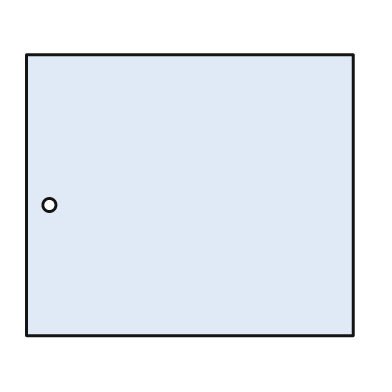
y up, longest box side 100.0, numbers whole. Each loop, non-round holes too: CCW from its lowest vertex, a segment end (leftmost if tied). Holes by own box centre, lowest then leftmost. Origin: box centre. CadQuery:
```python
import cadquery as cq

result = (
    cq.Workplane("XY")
    .moveTo(-50.0, -43.0)
    .lineTo(50.0, -43.0)
    .lineTo(50.0, 43.0)
    .lineTo(-50.0, 43.0)
    .close()
    .moveTo(-43.0, -3.0)
    .circle(2.0)
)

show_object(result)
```